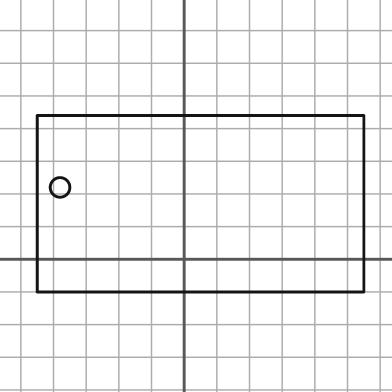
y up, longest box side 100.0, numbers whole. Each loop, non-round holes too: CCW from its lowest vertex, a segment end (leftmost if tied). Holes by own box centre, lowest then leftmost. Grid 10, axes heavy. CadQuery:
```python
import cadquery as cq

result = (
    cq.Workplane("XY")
    .moveTo(-45.0, -10.0)
    .lineTo(55.0, -10.0)
    .lineTo(55.0, 44.0)
    .lineTo(-45.0, 44.0)
    .close()
    .moveTo(-38.0, 22.0)
    .circle(3.0)
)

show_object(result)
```